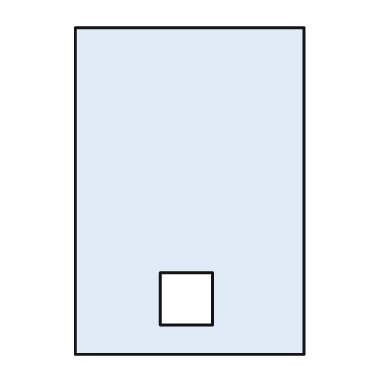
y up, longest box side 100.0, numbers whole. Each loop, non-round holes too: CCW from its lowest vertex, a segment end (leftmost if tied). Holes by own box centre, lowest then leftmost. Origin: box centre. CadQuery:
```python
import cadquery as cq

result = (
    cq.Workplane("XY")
    .moveTo(-35.0, -50.0)
    .lineTo(35.0, -50.0)
    .lineTo(35.0, 50.0)
    .lineTo(-35.0, 50.0)
    .close()
    .moveTo(-9.0, -41.0)
    .lineTo(7.0, -41.0)
    .lineTo(7.0, -25.0)
    .lineTo(-9.0, -25.0)
    .close()
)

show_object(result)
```